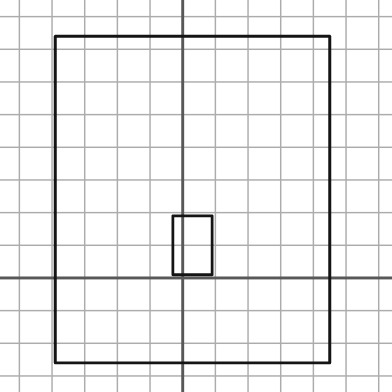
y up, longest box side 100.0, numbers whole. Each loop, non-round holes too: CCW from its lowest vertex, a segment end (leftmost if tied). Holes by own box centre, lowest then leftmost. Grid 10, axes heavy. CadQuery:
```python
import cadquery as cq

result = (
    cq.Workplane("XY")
    .moveTo(-39.0, -26.0)
    .lineTo(45.0, -26.0)
    .lineTo(45.0, 74.0)
    .lineTo(-39.0, 74.0)
    .close()
    .moveTo(-3.0, 1.0)
    .lineTo(9.0, 1.0)
    .lineTo(9.0, 19.0)
    .lineTo(-3.0, 19.0)
    .close()
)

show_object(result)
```